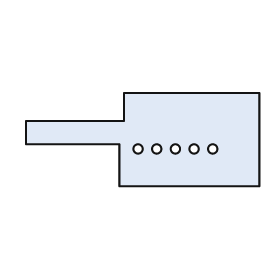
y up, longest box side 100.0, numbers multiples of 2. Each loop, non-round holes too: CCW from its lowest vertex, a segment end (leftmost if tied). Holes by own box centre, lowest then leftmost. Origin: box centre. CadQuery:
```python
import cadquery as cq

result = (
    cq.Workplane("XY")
    .moveTo(-10.0, -20.0)
    .lineTo(50.0, -20.0)
    .lineTo(50.0, 20.0)
    .lineTo(-8.0, 20.0)
    .lineTo(-8.0, 8.0)
    .lineTo(-50.0, 8.0)
    .lineTo(-50.0, -2.0)
    .lineTo(-10.0, -2.0)
    .close()
    .moveTo(-2.0, -4.0)
    .circle(2.0)
    .moveTo(6.0, -4.0)
    .circle(2.0)
    .moveTo(14.0, -4.0)
    .circle(2.0)
    .moveTo(22.0, -4.0)
    .circle(2.0)
    .moveTo(30.0, -4.0)
    .circle(2.0)
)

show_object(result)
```